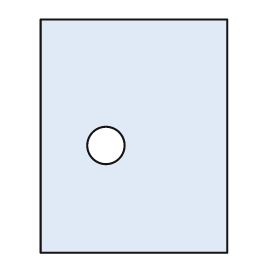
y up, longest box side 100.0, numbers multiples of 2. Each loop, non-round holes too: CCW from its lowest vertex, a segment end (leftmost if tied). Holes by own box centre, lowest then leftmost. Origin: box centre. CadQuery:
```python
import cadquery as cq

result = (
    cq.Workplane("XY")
    .moveTo(-40.0, -50.0)
    .lineTo(40.0, -50.0)
    .lineTo(40.0, 50.0)
    .lineTo(-40.0, 50.0)
    .close()
    .moveTo(-12.0, -4.0)
    .circle(8.0)
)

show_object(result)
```